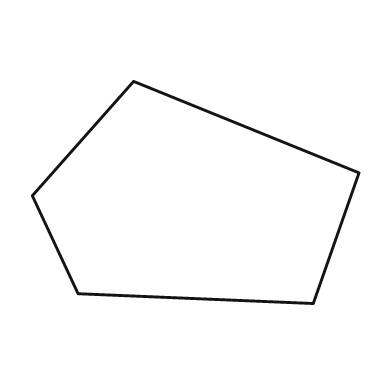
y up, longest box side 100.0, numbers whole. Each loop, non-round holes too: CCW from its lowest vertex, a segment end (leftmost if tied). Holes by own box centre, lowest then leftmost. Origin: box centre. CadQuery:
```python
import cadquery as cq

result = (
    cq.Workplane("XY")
    .moveTo(36.0, -34.0)
    .lineTo(50.0, 6.0)
    .lineTo(-19.0, 34.0)
    .lineTo(-50.0, -1.0)
    .lineTo(-36.0, -31.0)
    .close()
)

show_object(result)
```